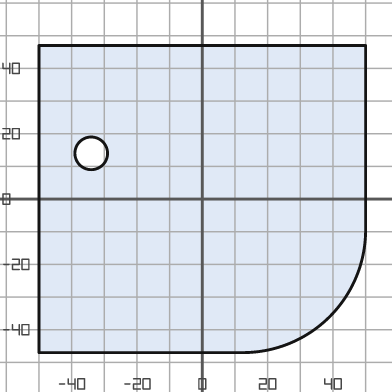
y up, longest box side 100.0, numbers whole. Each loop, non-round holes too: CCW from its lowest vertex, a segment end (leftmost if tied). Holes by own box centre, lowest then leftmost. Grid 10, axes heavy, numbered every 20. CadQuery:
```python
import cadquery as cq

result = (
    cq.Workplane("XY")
    .moveTo(-50.0, -47.0)
    .lineTo(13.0, -47.0)
    .threePointArc((39.0, -36.0), (50.0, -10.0))
    .lineTo(50.0, 47.0)
    .lineTo(-50.0, 47.0)
    .close()
    .moveTo(-34.0, 14.0)
    .circle(5.0)
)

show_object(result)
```